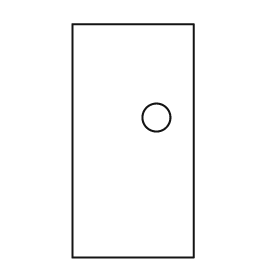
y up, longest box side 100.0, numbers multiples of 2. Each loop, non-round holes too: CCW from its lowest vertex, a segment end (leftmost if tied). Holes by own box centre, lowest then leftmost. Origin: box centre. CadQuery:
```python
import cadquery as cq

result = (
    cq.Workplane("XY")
    .moveTo(-26.0, -50.0)
    .lineTo(26.0, -50.0)
    .lineTo(26.0, 50.0)
    .lineTo(-26.0, 50.0)
    .close()
    .moveTo(10.0, 10.0)
    .circle(6.0)
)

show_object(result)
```